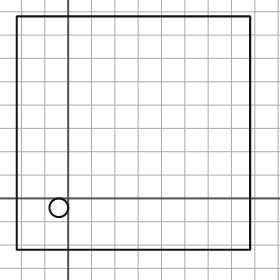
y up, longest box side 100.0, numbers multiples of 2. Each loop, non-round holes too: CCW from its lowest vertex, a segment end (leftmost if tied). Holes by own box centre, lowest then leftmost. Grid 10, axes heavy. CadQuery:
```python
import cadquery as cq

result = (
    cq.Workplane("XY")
    .moveTo(-22.0, -22.0)
    .lineTo(78.0, -22.0)
    .lineTo(78.0, 78.0)
    .lineTo(-22.0, 78.0)
    .close()
    .moveTo(-4.0, -4.0)
    .circle(4.0)
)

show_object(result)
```